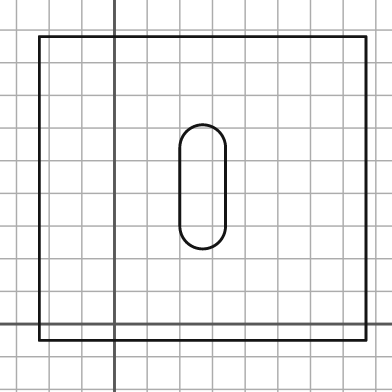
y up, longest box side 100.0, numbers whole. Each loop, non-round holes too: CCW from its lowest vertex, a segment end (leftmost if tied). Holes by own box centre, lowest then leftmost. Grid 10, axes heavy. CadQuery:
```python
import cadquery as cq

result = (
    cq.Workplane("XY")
    .moveTo(-23.0, -5.0)
    .lineTo(77.0, -5.0)
    .lineTo(77.0, 88.0)
    .lineTo(-23.0, 88.0)
    .close()
    .moveTo(20.0, 30.0)
    .threePointArc((27.0, 23.0), (34.0, 30.0))
    .lineTo(34.0, 54.0)
    .threePointArc((27.0, 61.0), (20.0, 54.0))
    .close()
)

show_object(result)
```